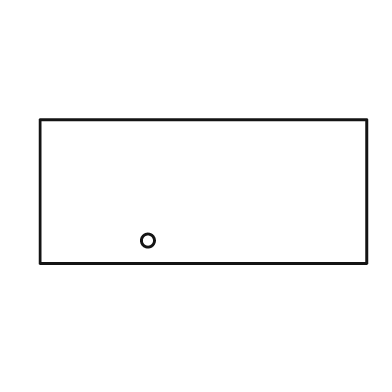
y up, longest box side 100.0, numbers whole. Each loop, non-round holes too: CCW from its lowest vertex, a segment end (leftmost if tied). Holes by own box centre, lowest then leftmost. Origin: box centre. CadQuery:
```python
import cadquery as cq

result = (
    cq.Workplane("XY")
    .moveTo(-50.0, -22.0)
    .lineTo(50.0, -22.0)
    .lineTo(50.0, 22.0)
    .lineTo(-50.0, 22.0)
    .close()
    .moveTo(-17.0, -15.0)
    .circle(2.0)
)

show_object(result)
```